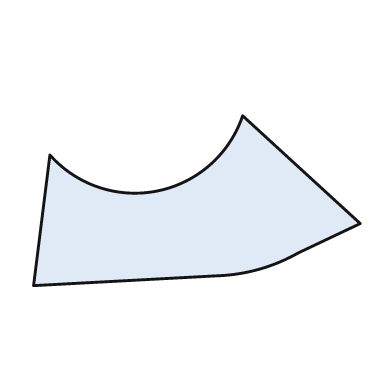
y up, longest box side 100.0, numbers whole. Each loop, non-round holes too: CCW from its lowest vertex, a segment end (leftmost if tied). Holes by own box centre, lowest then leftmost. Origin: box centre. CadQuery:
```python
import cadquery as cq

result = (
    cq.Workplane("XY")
    .moveTo(-50.0, -26.0)
    .lineTo(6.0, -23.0)
    .threePointArc((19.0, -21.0), (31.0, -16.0))
    .lineTo(50.0, -7.0)
    .lineTo(14.0, 26.0)
    .threePointArc((-12.0, 3.0), (-45.0, 14.0))
    .close()
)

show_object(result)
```